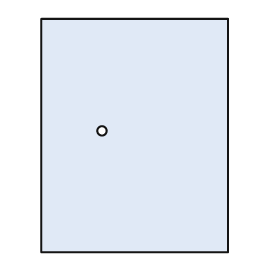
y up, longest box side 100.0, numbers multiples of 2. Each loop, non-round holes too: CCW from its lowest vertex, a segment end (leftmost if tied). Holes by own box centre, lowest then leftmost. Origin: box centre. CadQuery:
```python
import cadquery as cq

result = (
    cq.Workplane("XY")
    .moveTo(-40.0, -50.0)
    .lineTo(40.0, -50.0)
    .lineTo(40.0, 50.0)
    .lineTo(-40.0, 50.0)
    .close()
    .moveTo(-14.0, 2.0)
    .circle(2.0)
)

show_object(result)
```